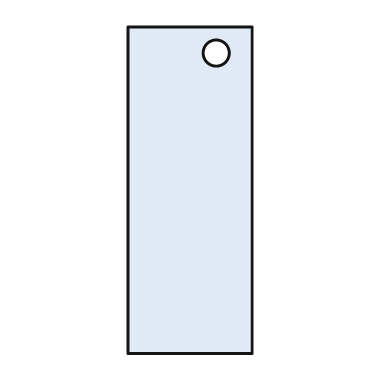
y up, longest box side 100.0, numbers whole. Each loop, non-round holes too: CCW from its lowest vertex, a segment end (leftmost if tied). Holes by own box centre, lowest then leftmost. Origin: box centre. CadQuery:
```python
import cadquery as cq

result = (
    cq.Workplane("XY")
    .moveTo(-19.0, -50.0)
    .lineTo(19.0, -50.0)
    .lineTo(19.0, 50.0)
    .lineTo(-19.0, 50.0)
    .close()
    .moveTo(8.0, 42.0)
    .circle(4.0)
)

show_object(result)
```